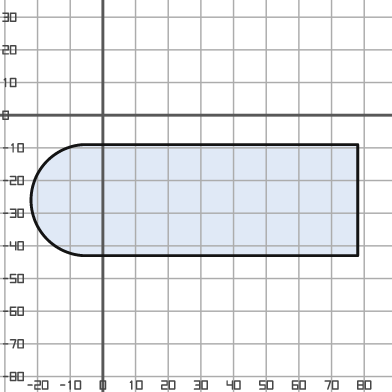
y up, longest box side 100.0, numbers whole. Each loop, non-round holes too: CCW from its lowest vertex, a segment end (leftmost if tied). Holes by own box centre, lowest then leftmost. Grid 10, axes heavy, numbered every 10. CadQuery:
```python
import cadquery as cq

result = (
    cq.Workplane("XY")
    .moveTo(-6.0, -43.0)
    .lineTo(78.0, -43.0)
    .lineTo(78.0, -9.0)
    .lineTo(-6.0, -9.0)
    .threePointArc((-22.0, -26.0), (-6.0, -43.0))
    .close()
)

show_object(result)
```